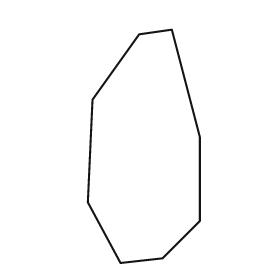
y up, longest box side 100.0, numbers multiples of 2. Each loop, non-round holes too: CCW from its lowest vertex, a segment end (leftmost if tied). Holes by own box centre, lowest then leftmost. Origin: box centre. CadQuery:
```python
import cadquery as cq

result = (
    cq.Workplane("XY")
    .moveTo(-10.0, -50.0)
    .lineTo(8.0, -48.0)
    .lineTo(24.0, -32.0)
    .lineTo(24.0, 4.0)
    .lineTo(12.0, 50.0)
    .lineTo(-2.0, 48.0)
    .lineTo(-22.0, 20.0)
    .lineTo(-24.0, -24.0)
    .close()
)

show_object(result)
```